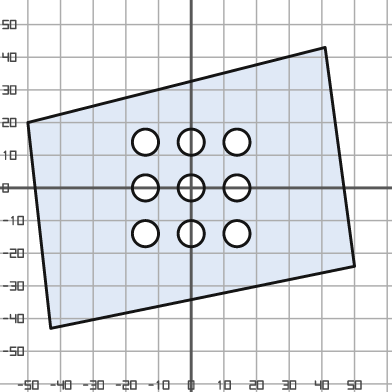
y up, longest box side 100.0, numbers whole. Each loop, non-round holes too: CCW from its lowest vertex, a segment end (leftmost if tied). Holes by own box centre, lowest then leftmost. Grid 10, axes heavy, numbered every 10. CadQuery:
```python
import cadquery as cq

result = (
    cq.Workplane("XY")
    .moveTo(-43.0, -43.0)
    .lineTo(50.0, -24.0)
    .lineTo(41.0, 43.0)
    .lineTo(-50.0, 20.0)
    .close()
    .moveTo(-14.0, -14.0)
    .circle(4.0)
    .moveTo(0.0, -14.0)
    .circle(4.0)
    .moveTo(14.0, -14.0)
    .circle(4.0)
    .moveTo(-14.0, 0.0)
    .circle(4.0)
    .moveTo(0.0, 0.0)
    .circle(4.0)
    .moveTo(14.0, 0.0)
    .circle(4.0)
    .moveTo(-14.0, 14.0)
    .circle(4.0)
    .moveTo(0.0, 14.0)
    .circle(4.0)
    .moveTo(14.0, 14.0)
    .circle(4.0)
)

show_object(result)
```